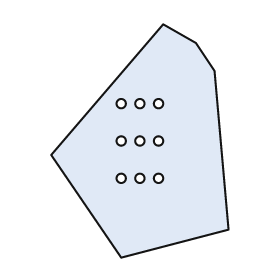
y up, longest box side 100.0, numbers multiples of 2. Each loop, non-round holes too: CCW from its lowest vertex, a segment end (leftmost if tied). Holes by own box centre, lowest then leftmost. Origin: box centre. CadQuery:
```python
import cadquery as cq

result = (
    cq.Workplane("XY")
    .moveTo(-8.0, -50.0)
    .lineTo(38.0, -38.0)
    .lineTo(32.0, 30.0)
    .lineTo(24.0, 42.0)
    .lineTo(10.0, 50.0)
    .lineTo(-38.0, -6.0)
    .close()
    .moveTo(-8.0, -16.0)
    .circle(2.0)
    .moveTo(0.0, -16.0)
    .circle(2.0)
    .moveTo(8.0, -16.0)
    .circle(2.0)
    .moveTo(-8.0, 0.0)
    .circle(2.0)
    .moveTo(0.0, 0.0)
    .circle(2.0)
    .moveTo(8.0, 0.0)
    .circle(2.0)
    .moveTo(-8.0, 16.0)
    .circle(2.0)
    .moveTo(0.0, 16.0)
    .circle(2.0)
    .moveTo(8.0, 16.0)
    .circle(2.0)
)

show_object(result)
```